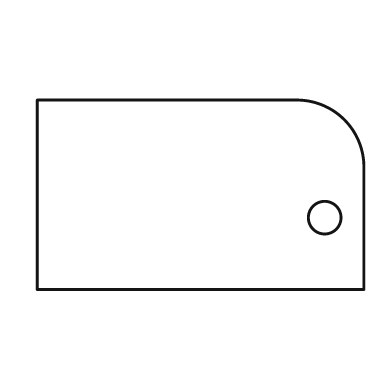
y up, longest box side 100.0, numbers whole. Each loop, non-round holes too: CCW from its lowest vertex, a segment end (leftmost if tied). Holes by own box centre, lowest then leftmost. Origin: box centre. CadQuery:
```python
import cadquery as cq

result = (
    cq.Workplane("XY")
    .moveTo(-50.0, -29.0)
    .lineTo(50.0, -29.0)
    .lineTo(50.0, 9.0)
    .threePointArc((44.0, 23.0), (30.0, 29.0))
    .lineTo(-50.0, 29.0)
    .close()
    .moveTo(38.0, -7.0)
    .circle(5.0)
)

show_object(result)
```